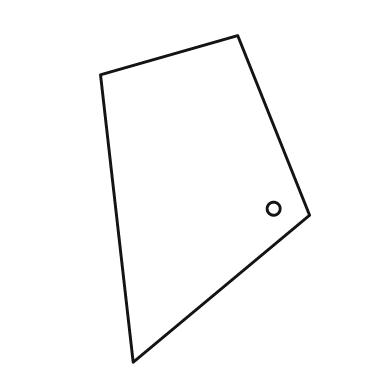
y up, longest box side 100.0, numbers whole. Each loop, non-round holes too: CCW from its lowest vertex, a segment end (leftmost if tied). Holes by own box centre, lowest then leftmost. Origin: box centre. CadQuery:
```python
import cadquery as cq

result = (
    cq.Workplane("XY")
    .moveTo(-22.0, -50.0)
    .lineTo(32.0, -5.0)
    .lineTo(10.0, 50.0)
    .lineTo(-32.0, 38.0)
    .close()
    .moveTo(21.0, -3.0)
    .circle(2.0)
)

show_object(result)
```